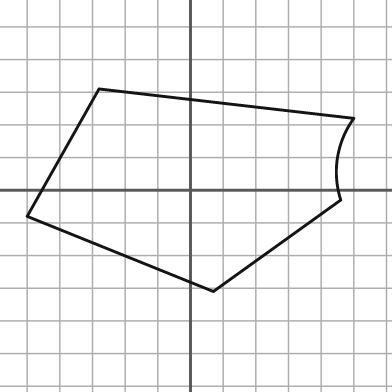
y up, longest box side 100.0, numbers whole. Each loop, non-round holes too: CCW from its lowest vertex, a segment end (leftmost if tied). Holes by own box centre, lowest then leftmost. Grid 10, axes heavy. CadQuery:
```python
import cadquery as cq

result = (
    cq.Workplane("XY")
    .moveTo(7.0, -31.0)
    .lineTo(46.0, -3.0)
    .threePointArc((45.0, 10.0), (50.0, 22.0))
    .lineTo(-28.0, 31.0)
    .lineTo(-50.0, -8.0)
    .close()
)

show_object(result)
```